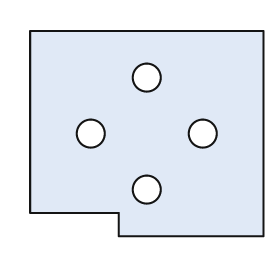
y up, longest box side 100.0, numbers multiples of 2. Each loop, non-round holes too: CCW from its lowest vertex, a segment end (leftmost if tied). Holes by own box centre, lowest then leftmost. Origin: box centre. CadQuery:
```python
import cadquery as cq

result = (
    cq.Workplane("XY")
    .moveTo(-12.0, -44.0)
    .lineTo(50.0, -44.0)
    .lineTo(50.0, 44.0)
    .lineTo(-50.0, 44.0)
    .lineTo(-50.0, -34.0)
    .lineTo(-12.0, -34.0)
    .close()
    .moveTo(0.0, -24.0)
    .circle(6.0)
    .moveTo(-24.0, 0.0)
    .circle(6.0)
    .moveTo(24.0, 0.0)
    .circle(6.0)
    .moveTo(0.0, 24.0)
    .circle(6.0)
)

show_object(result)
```